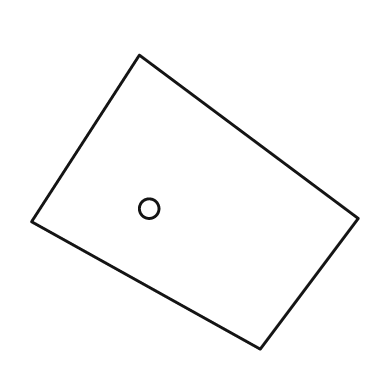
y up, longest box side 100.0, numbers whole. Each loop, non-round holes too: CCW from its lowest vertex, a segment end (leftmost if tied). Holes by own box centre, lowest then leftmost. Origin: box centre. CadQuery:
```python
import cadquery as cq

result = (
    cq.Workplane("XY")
    .moveTo(20.0, -45.0)
    .lineTo(50.0, -5.0)
    .lineTo(-17.0, 45.0)
    .lineTo(-50.0, -6.0)
    .close()
    .moveTo(-14.0, -2.0)
    .circle(3.0)
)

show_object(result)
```